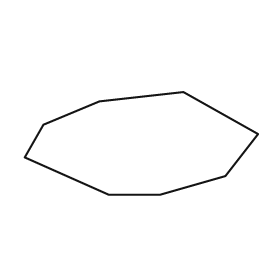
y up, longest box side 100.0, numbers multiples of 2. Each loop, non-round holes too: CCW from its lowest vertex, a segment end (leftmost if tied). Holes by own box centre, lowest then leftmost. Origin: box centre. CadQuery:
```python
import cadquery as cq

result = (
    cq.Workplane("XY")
    .moveTo(-14.0, -22.0)
    .lineTo(8.0, -22.0)
    .lineTo(36.0, -14.0)
    .lineTo(50.0, 4.0)
    .lineTo(18.0, 22.0)
    .lineTo(-18.0, 18.0)
    .lineTo(-42.0, 8.0)
    .lineTo(-50.0, -6.0)
    .close()
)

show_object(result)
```